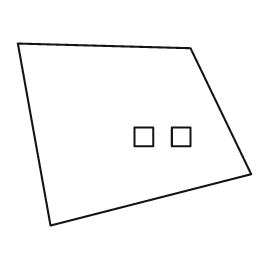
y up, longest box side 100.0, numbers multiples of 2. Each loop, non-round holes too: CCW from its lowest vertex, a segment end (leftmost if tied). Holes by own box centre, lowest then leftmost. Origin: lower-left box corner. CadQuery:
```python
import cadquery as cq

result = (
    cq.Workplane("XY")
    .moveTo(14.0, 0.0)
    .lineTo(100.0, 22.0)
    .lineTo(74.0, 76.0)
    .lineTo(0.0, 78.0)
    .close()
    .moveTo(50.0, 34.0)
    .lineTo(58.0, 34.0)
    .lineTo(58.0, 42.0)
    .lineTo(50.0, 42.0)
    .close()
    .moveTo(66.0, 34.0)
    .lineTo(74.0, 34.0)
    .lineTo(74.0, 42.0)
    .lineTo(66.0, 42.0)
    .close()
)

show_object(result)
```